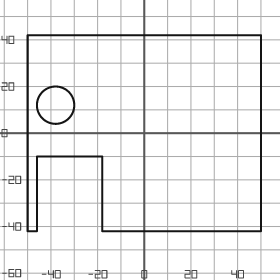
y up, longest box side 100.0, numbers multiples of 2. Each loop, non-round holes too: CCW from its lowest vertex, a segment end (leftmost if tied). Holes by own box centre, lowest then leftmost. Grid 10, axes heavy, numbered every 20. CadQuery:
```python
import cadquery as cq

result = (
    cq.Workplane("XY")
    .moveTo(-50.0, -42.0)
    .lineTo(-46.0, -42.0)
    .lineTo(-46.0, -10.0)
    .lineTo(-18.0, -10.0)
    .lineTo(-18.0, -42.0)
    .lineTo(50.0, -42.0)
    .lineTo(50.0, 42.0)
    .lineTo(-50.0, 42.0)
    .close()
    .moveTo(-38.0, 12.0)
    .circle(8.0)
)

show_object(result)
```